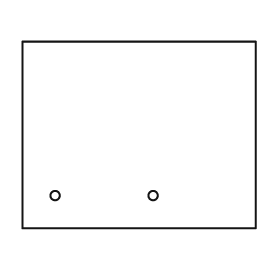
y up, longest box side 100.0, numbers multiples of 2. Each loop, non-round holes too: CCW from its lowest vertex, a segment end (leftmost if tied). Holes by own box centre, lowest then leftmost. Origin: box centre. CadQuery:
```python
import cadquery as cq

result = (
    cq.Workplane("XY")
    .moveTo(-50.0, -40.0)
    .lineTo(50.0, -40.0)
    .lineTo(50.0, 40.0)
    .lineTo(-50.0, 40.0)
    .close()
    .moveTo(-36.0, -26.0)
    .circle(2.0)
    .moveTo(6.0, -26.0)
    .circle(2.0)
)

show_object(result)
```